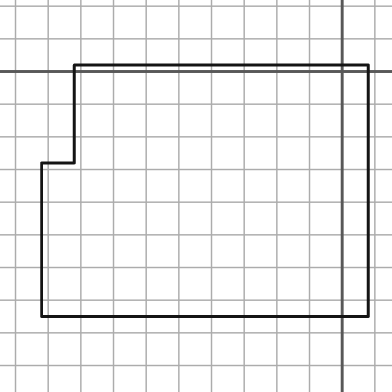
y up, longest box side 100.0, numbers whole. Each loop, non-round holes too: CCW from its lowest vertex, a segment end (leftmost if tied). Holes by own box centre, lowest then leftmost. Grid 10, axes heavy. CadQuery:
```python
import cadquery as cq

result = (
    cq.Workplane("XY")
    .moveTo(-92.0, -75.0)
    .lineTo(8.0, -75.0)
    .lineTo(8.0, 2.0)
    .lineTo(-82.0, 2.0)
    .lineTo(-82.0, -28.0)
    .lineTo(-92.0, -28.0)
    .close()
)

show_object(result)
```